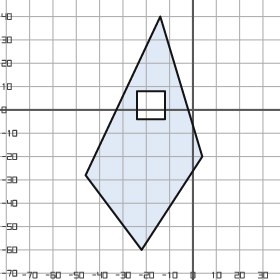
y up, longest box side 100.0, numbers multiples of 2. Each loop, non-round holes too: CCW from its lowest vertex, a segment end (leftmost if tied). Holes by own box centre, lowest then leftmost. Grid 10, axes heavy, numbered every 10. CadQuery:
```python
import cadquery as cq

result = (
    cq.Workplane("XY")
    .moveTo(-22.0, -60.0)
    .lineTo(4.0, -20.0)
    .lineTo(-14.0, 40.0)
    .lineTo(-46.0, -28.0)
    .close()
    .moveTo(-24.0, -4.0)
    .lineTo(-12.0, -4.0)
    .lineTo(-12.0, 8.0)
    .lineTo(-24.0, 8.0)
    .close()
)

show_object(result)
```